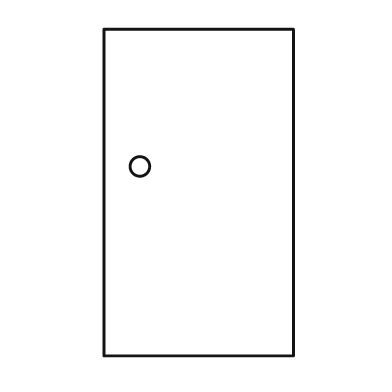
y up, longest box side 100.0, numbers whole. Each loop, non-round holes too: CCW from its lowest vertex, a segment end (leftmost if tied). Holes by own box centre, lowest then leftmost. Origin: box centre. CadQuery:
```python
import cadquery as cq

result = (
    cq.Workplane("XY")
    .moveTo(-29.0, -50.0)
    .lineTo(29.0, -50.0)
    .lineTo(29.0, 50.0)
    .lineTo(-29.0, 50.0)
    .close()
    .moveTo(-18.0, 8.0)
    .circle(3.0)
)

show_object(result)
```